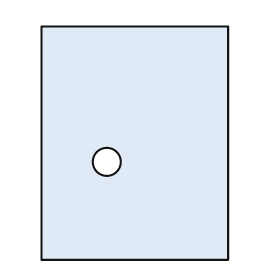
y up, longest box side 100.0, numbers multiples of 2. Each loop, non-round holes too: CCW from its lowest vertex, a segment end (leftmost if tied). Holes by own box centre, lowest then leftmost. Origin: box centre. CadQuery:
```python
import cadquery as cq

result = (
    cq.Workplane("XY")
    .moveTo(-40.0, -50.0)
    .lineTo(40.0, -50.0)
    .lineTo(40.0, 50.0)
    .lineTo(-40.0, 50.0)
    .close()
    .moveTo(-12.0, -8.0)
    .circle(6.0)
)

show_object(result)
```